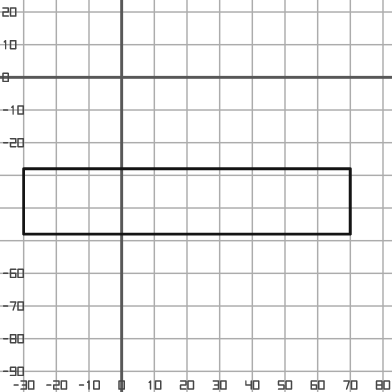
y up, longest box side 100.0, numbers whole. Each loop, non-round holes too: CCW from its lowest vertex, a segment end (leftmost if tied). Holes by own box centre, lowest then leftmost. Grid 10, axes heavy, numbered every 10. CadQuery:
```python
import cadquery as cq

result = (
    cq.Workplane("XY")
    .moveTo(-30.0, -48.0)
    .lineTo(70.0, -48.0)
    .lineTo(70.0, -28.0)
    .lineTo(-30.0, -28.0)
    .close()
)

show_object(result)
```